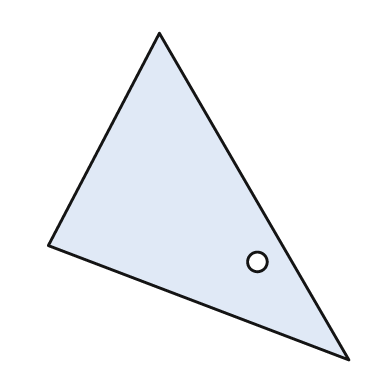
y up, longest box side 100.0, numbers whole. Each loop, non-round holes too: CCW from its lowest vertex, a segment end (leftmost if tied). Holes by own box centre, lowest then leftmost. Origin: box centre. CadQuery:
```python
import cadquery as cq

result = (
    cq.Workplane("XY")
    .moveTo(46.0, -50.0)
    .lineTo(-12.0, 50.0)
    .lineTo(-46.0, -15.0)
    .close()
    .moveTo(18.0, -20.0)
    .circle(3.0)
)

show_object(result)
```